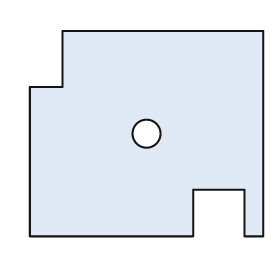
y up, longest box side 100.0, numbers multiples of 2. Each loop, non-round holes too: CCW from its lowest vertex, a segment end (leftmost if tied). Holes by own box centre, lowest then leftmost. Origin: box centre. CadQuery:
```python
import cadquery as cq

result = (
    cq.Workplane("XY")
    .moveTo(-50.0, -44.0)
    .lineTo(20.0, -44.0)
    .lineTo(20.0, -24.0)
    .lineTo(42.0, -24.0)
    .lineTo(42.0, -44.0)
    .lineTo(50.0, -44.0)
    .lineTo(50.0, 44.0)
    .lineTo(-36.0, 44.0)
    .lineTo(-36.0, 20.0)
    .lineTo(-50.0, 20.0)
    .close()
    .moveTo(0.0, 0.0)
    .circle(6.0)
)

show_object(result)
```